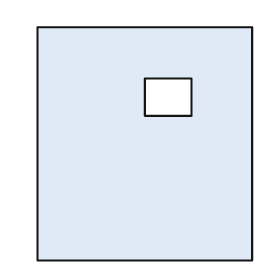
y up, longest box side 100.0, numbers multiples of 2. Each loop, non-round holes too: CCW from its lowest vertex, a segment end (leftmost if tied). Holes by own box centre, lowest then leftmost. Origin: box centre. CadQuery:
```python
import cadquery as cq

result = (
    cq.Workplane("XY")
    .moveTo(-46.0, -50.0)
    .lineTo(46.0, -50.0)
    .lineTo(46.0, 50.0)
    .lineTo(-46.0, 50.0)
    .close()
    .moveTo(0.0, 12.0)
    .lineTo(20.0, 12.0)
    .lineTo(20.0, 28.0)
    .lineTo(0.0, 28.0)
    .close()
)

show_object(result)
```